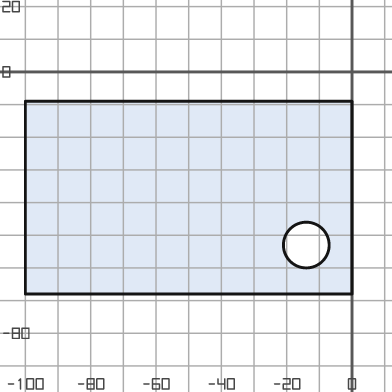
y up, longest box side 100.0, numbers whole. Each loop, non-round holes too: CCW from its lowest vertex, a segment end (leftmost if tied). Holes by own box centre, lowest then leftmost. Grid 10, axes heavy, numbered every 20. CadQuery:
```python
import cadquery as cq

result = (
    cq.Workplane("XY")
    .moveTo(-100.0, -68.0)
    .lineTo(0.0, -68.0)
    .lineTo(0.0, -9.0)
    .lineTo(-100.0, -9.0)
    .close()
    .moveTo(-14.0, -53.0)
    .circle(7.0)
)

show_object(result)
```